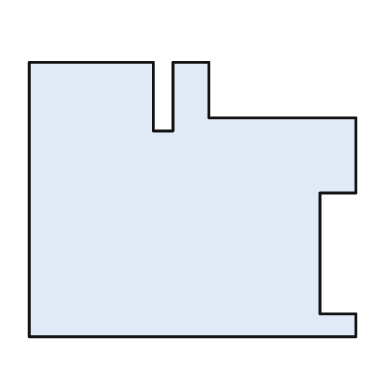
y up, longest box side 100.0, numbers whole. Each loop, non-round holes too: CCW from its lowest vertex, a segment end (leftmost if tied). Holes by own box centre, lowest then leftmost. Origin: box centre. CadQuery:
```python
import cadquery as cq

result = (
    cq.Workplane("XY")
    .moveTo(-50.0, -42.0)
    .lineTo(50.0, -42.0)
    .lineTo(50.0, -35.0)
    .lineTo(39.0, -35.0)
    .lineTo(39.0, 2.0)
    .lineTo(50.0, 2.0)
    .lineTo(50.0, 25.0)
    .lineTo(5.0, 25.0)
    .lineTo(5.0, 42.0)
    .lineTo(-6.0, 42.0)
    .lineTo(-6.0, 21.0)
    .lineTo(-12.0, 21.0)
    .lineTo(-12.0, 42.0)
    .lineTo(-50.0, 42.0)
    .close()
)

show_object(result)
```